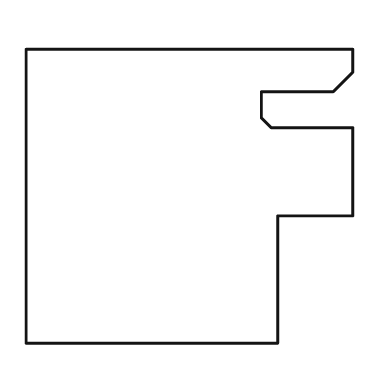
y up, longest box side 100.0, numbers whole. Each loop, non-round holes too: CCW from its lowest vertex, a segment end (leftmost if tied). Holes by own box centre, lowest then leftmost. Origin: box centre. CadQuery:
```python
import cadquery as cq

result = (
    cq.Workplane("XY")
    .moveTo(-50.0, -45.0)
    .lineTo(27.0, -45.0)
    .lineTo(27.0, -6.0)
    .lineTo(50.0, -6.0)
    .lineTo(50.0, 21.0)
    .lineTo(25.0, 21.0)
    .lineTo(22.0, 24.0)
    .lineTo(22.0, 32.0)
    .lineTo(44.0, 32.0)
    .lineTo(50.0, 38.0)
    .lineTo(50.0, 45.0)
    .lineTo(-50.0, 45.0)
    .close()
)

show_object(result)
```